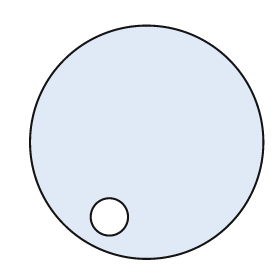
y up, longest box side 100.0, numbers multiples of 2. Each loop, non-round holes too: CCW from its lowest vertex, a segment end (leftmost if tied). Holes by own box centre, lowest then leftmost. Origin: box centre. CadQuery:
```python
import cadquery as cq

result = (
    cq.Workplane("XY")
    .moveTo(0.0, 0.0)
    .circle(50.0)
    .moveTo(-16.0, -32.0)
    .circle(8.0)
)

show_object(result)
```